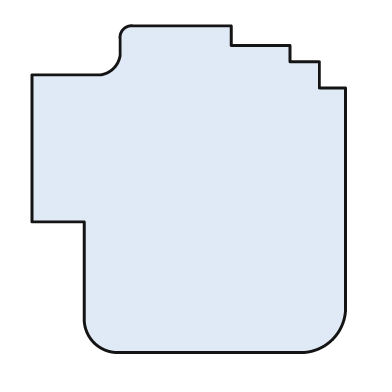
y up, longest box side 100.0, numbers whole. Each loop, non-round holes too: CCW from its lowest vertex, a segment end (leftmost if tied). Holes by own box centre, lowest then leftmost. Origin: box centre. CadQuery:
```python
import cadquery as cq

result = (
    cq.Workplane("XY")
    .moveTo(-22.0, -50.0)
    .lineTo(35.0, -50.0)
    .threePointArc((44.0, -46.0), (48.0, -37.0))
    .lineTo(48.0, 31.0)
    .lineTo(40.0, 31.0)
    .lineTo(40.0, 39.0)
    .lineTo(31.0, 39.0)
    .lineTo(31.0, 44.0)
    .lineTo(13.0, 44.0)
    .lineTo(13.0, 50.0)
    .lineTo(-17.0, 50.0)
    .threePointArc((-20.0, 49.0), (-21.0, 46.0))
    .lineTo(-21.0, 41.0)
    .threePointArc((-23.0, 37.0), (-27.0, 35.0))
    .lineTo(-48.0, 35.0)
    .lineTo(-48.0, -10.0)
    .lineTo(-32.0, -10.0)
    .lineTo(-32.0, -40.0)
    .threePointArc((-29.0, -47.0), (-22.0, -50.0))
    .close()
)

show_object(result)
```